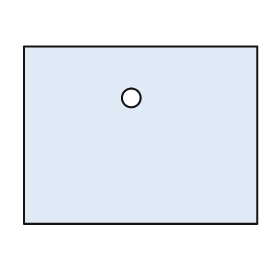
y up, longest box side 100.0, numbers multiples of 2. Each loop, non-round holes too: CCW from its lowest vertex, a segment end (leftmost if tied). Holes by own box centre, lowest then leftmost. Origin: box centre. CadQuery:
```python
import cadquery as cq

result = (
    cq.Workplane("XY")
    .moveTo(-50.0, -38.0)
    .lineTo(50.0, -38.0)
    .lineTo(50.0, 38.0)
    .lineTo(-50.0, 38.0)
    .close()
    .moveTo(-4.0, 16.0)
    .circle(4.0)
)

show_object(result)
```